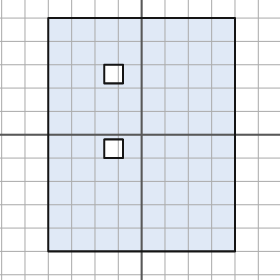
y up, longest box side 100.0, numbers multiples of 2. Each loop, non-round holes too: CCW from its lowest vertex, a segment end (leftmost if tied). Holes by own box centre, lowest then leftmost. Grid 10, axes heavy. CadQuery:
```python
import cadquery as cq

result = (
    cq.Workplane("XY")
    .moveTo(-40.0, -50.0)
    .lineTo(40.0, -50.0)
    .lineTo(40.0, 50.0)
    .lineTo(-40.0, 50.0)
    .close()
    .moveTo(-16.0, -10.0)
    .lineTo(-8.0, -10.0)
    .lineTo(-8.0, -2.0)
    .lineTo(-16.0, -2.0)
    .close()
    .moveTo(-16.0, 22.0)
    .lineTo(-8.0, 22.0)
    .lineTo(-8.0, 30.0)
    .lineTo(-16.0, 30.0)
    .close()
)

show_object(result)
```